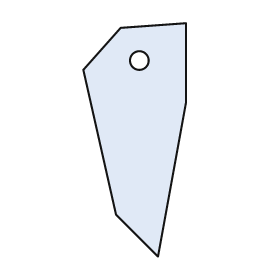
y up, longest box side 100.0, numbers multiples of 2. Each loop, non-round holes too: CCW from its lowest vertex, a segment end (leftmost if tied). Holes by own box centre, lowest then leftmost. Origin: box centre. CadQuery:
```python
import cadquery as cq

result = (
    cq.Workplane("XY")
    .moveTo(10.0, -50.0)
    .lineTo(22.0, 16.0)
    .lineTo(22.0, 50.0)
    .lineTo(-6.0, 48.0)
    .lineTo(-22.0, 30.0)
    .lineTo(-8.0, -32.0)
    .close()
    .moveTo(2.0, 34.0)
    .circle(4.0)
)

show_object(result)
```